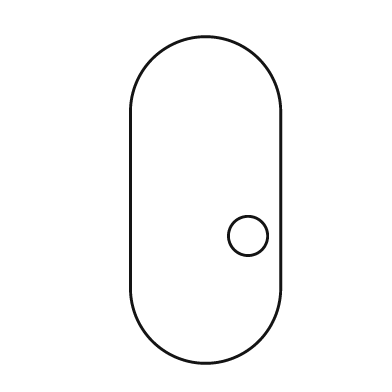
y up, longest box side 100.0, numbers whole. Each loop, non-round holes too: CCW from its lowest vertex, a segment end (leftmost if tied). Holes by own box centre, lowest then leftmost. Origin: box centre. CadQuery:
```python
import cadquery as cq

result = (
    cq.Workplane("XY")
    .moveTo(-23.0, -27.0)
    .threePointArc((0.0, -50.0), (23.0, -27.0))
    .lineTo(23.0, 27.0)
    .threePointArc((0.0, 50.0), (-23.0, 27.0))
    .close()
    .moveTo(13.0, -11.0)
    .circle(6.0)
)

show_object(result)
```